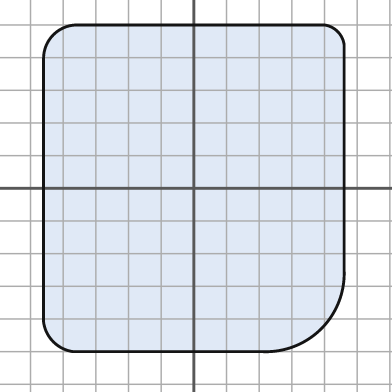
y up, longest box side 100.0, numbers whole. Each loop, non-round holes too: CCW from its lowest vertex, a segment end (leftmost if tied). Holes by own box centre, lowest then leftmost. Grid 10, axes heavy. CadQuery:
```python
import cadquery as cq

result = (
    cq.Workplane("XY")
    .moveTo(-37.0, -50.0)
    .lineTo(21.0, -50.0)
    .threePointArc((39.0, -43.0), (46.0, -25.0))
    .lineTo(46.0, 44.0)
    .threePointArc((44.0, 48.0), (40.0, 50.0))
    .lineTo(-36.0, 50.0)
    .threePointArc((-43.0, 47.0), (-46.0, 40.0))
    .lineTo(-46.0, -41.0)
    .threePointArc((-43.0, -47.0), (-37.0, -50.0))
    .close()
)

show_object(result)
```